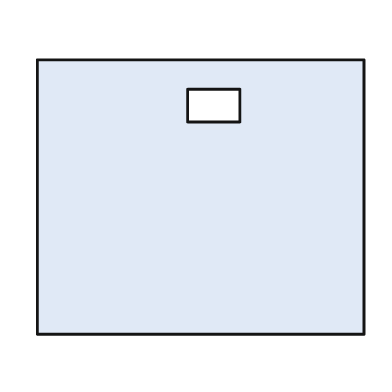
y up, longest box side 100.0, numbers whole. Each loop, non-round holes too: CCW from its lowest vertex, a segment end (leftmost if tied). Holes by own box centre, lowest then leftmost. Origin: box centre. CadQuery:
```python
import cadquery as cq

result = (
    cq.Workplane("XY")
    .moveTo(-50.0, -42.0)
    .lineTo(50.0, -42.0)
    .lineTo(50.0, 42.0)
    .lineTo(-50.0, 42.0)
    .close()
    .moveTo(-4.0, 23.0)
    .lineTo(12.0, 23.0)
    .lineTo(12.0, 33.0)
    .lineTo(-4.0, 33.0)
    .close()
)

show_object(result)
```